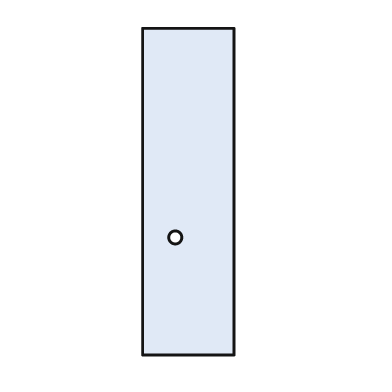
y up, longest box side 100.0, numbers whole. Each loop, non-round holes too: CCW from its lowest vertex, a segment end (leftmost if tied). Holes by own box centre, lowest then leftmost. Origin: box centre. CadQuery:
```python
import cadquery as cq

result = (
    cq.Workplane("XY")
    .moveTo(-14.0, -50.0)
    .lineTo(14.0, -50.0)
    .lineTo(14.0, 50.0)
    .lineTo(-14.0, 50.0)
    .close()
    .moveTo(-4.0, -14.0)
    .circle(2.0)
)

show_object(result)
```